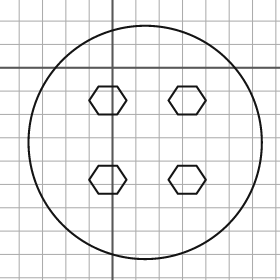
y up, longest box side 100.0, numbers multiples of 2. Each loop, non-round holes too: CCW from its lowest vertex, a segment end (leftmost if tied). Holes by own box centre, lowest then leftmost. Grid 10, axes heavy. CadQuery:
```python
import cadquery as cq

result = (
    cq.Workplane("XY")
    .moveTo(14.0, -32.0)
    .circle(50.0)
    .moveTo(-6.0, -54.0)
    .lineTo(2.0, -54.0)
    .lineTo(6.0, -48.0)
    .lineTo(2.0, -42.0)
    .lineTo(-6.0, -42.0)
    .lineTo(-10.0, -48.0)
    .close()
    .moveTo(28.0, -54.0)
    .lineTo(36.0, -54.0)
    .lineTo(40.0, -48.0)
    .lineTo(36.0, -42.0)
    .lineTo(28.0, -42.0)
    .lineTo(24.0, -48.0)
    .close()
    .moveTo(-6.0, -20.0)
    .lineTo(2.0, -20.0)
    .lineTo(6.0, -14.0)
    .lineTo(2.0, -8.0)
    .lineTo(-6.0, -8.0)
    .lineTo(-10.0, -14.0)
    .close()
    .moveTo(28.0, -20.0)
    .lineTo(36.0, -20.0)
    .lineTo(40.0, -14.0)
    .lineTo(36.0, -8.0)
    .lineTo(28.0, -8.0)
    .lineTo(24.0, -14.0)
    .close()
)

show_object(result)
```